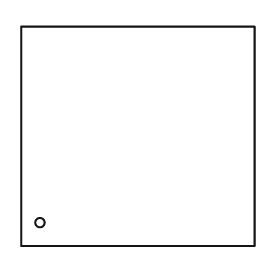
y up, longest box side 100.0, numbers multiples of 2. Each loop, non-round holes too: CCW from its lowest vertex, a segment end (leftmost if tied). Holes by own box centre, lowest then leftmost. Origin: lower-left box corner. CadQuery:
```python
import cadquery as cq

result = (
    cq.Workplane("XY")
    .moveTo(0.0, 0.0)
    .lineTo(100.0, 0.0)
    .lineTo(100.0, 94.0)
    .lineTo(0.0, 94.0)
    .close()
    .moveTo(8.0, 10.0)
    .circle(2.0)
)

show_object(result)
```